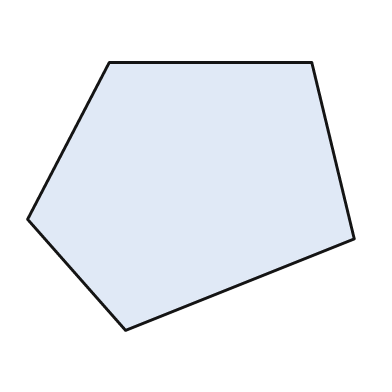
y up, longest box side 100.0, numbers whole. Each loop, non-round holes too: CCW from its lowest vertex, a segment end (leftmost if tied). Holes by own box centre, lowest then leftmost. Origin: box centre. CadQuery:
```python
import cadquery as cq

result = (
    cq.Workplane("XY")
    .moveTo(-20.0, -41.0)
    .lineTo(50.0, -13.0)
    .lineTo(37.0, 41.0)
    .lineTo(-25.0, 41.0)
    .lineTo(-50.0, -7.0)
    .close()
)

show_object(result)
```